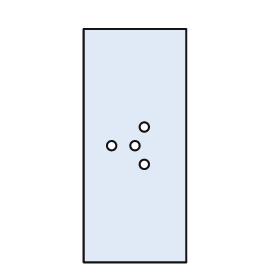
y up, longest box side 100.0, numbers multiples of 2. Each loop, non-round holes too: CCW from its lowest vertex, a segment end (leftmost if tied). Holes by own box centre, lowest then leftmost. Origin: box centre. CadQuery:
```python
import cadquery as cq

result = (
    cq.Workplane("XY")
    .moveTo(-22.0, -50.0)
    .lineTo(22.0, -50.0)
    .lineTo(22.0, 50.0)
    .lineTo(-22.0, 50.0)
    .close()
    .moveTo(4.0, -8.0)
    .circle(2.0)
    .moveTo(-10.0, 0.0)
    .circle(2.0)
    .moveTo(0.0, 0.0)
    .circle(2.0)
    .moveTo(4.0, 8.0)
    .circle(2.0)
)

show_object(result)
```